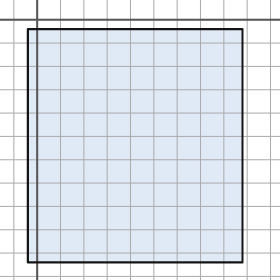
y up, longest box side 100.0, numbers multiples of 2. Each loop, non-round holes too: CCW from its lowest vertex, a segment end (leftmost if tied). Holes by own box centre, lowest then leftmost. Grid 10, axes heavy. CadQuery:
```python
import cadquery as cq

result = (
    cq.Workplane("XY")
    .moveTo(-4.0, -104.0)
    .lineTo(88.0, -104.0)
    .lineTo(88.0, -4.0)
    .lineTo(-4.0, -4.0)
    .close()
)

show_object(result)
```